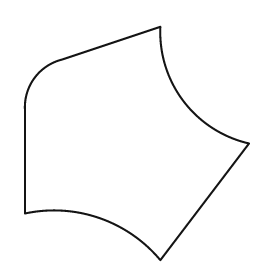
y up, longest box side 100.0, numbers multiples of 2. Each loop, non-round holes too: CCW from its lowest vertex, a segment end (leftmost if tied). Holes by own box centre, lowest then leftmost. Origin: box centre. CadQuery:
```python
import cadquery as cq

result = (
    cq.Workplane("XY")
    .moveTo(10.0, -50.0)
    .lineTo(48.0, 0.0)
    .threePointArc((20.0, 18.0), (10.0, 50.0))
    .lineTo(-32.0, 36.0)
    .threePointArc((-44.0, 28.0), (-48.0, 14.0))
    .lineTo(-48.0, -30.0)
    .threePointArc((-16.0, -32.0), (10.0, -50.0))
    .close()
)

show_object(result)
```